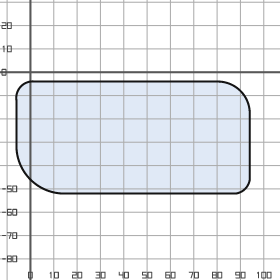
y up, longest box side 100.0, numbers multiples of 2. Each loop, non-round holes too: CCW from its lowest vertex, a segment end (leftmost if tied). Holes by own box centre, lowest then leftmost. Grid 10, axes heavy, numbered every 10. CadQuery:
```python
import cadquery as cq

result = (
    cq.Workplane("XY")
    .moveTo(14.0, -52.0)
    .lineTo(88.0, -52.0)
    .threePointArc((92.0, -50.0), (94.0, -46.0))
    .lineTo(94.0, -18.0)
    .threePointArc((90.0, -8.0), (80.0, -4.0))
    .lineTo(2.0, -4.0)
    .threePointArc((-4.0, -6.0), (-6.0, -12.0))
    .lineTo(-6.0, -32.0)
    .threePointArc((0.0, -46.0), (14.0, -52.0))
    .close()
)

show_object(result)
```